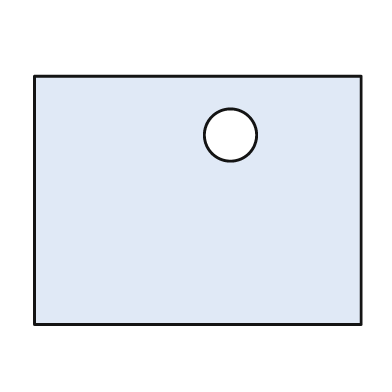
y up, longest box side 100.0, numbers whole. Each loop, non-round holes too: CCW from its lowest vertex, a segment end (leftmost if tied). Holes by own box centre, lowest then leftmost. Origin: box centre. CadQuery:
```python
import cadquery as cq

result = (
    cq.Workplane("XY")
    .moveTo(-50.0, -38.0)
    .lineTo(50.0, -38.0)
    .lineTo(50.0, 38.0)
    .lineTo(-50.0, 38.0)
    .close()
    .moveTo(10.0, 20.0)
    .circle(8.0)
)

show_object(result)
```